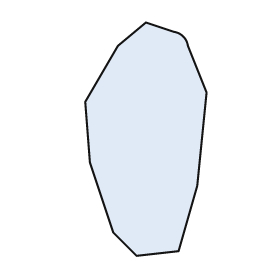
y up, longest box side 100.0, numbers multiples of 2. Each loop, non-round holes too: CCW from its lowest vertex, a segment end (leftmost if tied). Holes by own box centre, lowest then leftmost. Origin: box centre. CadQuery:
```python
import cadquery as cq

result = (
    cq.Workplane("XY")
    .moveTo(-4.0, -50.0)
    .lineTo(14.0, -48.0)
    .lineTo(22.0, -20.0)
    .lineTo(26.0, 20.0)
    .lineTo(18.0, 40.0)
    .threePointArc((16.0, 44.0), (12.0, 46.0))
    .lineTo(0.0, 50.0)
    .lineTo(-12.0, 40.0)
    .lineTo(-26.0, 16.0)
    .lineTo(-24.0, -10.0)
    .lineTo(-14.0, -40.0)
    .close()
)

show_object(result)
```